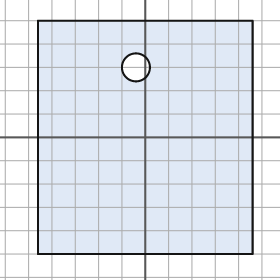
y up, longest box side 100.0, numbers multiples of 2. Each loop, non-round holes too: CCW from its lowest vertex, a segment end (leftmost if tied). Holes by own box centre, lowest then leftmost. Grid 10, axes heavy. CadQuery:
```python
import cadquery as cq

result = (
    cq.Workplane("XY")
    .moveTo(-46.0, -50.0)
    .lineTo(46.0, -50.0)
    .lineTo(46.0, 50.0)
    .lineTo(-46.0, 50.0)
    .close()
    .moveTo(-4.0, 30.0)
    .circle(6.0)
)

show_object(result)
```